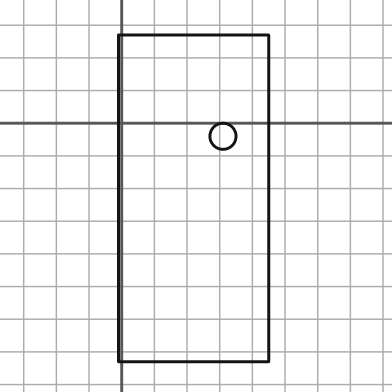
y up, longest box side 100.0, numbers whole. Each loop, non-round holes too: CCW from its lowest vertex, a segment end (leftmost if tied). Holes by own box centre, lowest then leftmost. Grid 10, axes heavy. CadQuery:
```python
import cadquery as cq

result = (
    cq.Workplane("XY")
    .moveTo(-1.0, -73.0)
    .lineTo(45.0, -73.0)
    .lineTo(45.0, 27.0)
    .lineTo(-1.0, 27.0)
    .close()
    .moveTo(31.0, -4.0)
    .circle(4.0)
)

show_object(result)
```